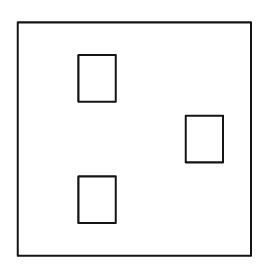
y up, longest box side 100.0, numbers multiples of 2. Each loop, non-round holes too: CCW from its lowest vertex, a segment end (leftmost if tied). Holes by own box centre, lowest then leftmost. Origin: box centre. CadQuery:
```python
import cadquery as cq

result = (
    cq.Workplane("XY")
    .moveTo(-50.0, -50.0)
    .lineTo(50.0, -50.0)
    .lineTo(50.0, 50.0)
    .lineTo(-50.0, 50.0)
    .close()
    .moveTo(-24.0, -36.0)
    .lineTo(-8.0, -36.0)
    .lineTo(-8.0, -16.0)
    .lineTo(-24.0, -16.0)
    .close()
    .moveTo(22.0, -10.0)
    .lineTo(38.0, -10.0)
    .lineTo(38.0, 10.0)
    .lineTo(22.0, 10.0)
    .close()
    .moveTo(-24.0, 16.0)
    .lineTo(-8.0, 16.0)
    .lineTo(-8.0, 36.0)
    .lineTo(-24.0, 36.0)
    .close()
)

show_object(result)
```